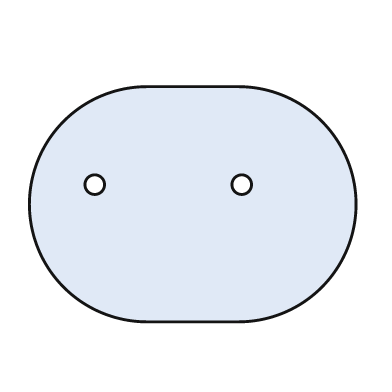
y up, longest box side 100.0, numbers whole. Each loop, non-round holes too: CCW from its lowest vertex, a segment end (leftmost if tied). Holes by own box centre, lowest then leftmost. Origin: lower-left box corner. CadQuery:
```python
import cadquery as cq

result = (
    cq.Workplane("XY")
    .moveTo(36.0, 0.0)
    .lineTo(64.0, 0.0)
    .threePointArc((100.0, 36.0), (64.0, 72.0))
    .lineTo(36.0, 72.0)
    .threePointArc((0.0, 36.0), (36.0, 0.0))
    .close()
    .moveTo(20.0, 42.0)
    .circle(3.0)
    .moveTo(65.0, 42.0)
    .circle(3.0)
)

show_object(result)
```